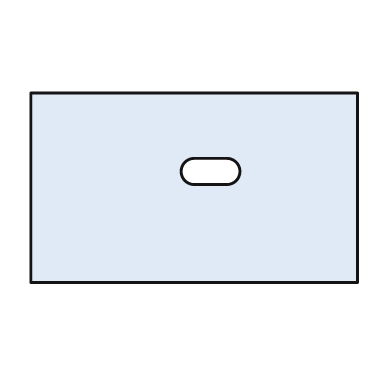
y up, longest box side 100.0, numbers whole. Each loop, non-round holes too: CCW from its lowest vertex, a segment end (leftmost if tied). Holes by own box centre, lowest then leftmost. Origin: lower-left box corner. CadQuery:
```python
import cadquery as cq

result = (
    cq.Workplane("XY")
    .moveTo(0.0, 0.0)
    .lineTo(100.0, 0.0)
    .lineTo(100.0, 58.0)
    .lineTo(0.0, 58.0)
    .close()
    .moveTo(50.0, 30.0)
    .lineTo(60.0, 30.0)
    .threePointArc((64.0, 34.0), (60.0, 38.0))
    .lineTo(50.0, 38.0)
    .threePointArc((46.0, 34.0), (50.0, 30.0))
    .close()
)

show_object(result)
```